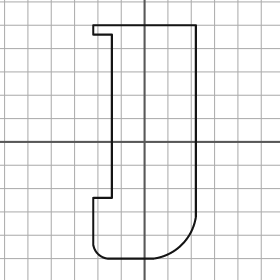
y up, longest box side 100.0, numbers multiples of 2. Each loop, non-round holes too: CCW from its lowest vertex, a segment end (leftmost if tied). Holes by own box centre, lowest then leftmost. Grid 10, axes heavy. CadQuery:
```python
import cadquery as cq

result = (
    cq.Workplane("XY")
    .moveTo(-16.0, -50.0)
    .lineTo(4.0, -50.0)
    .threePointArc((16.0, -44.0), (22.0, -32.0))
    .lineTo(22.0, 50.0)
    .lineTo(-22.0, 50.0)
    .lineTo(-22.0, 46.0)
    .lineTo(-14.0, 46.0)
    .lineTo(-14.0, -24.0)
    .lineTo(-22.0, -24.0)
    .lineTo(-22.0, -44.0)
    .threePointArc((-20.0, -48.0), (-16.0, -50.0))
    .close()
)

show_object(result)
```